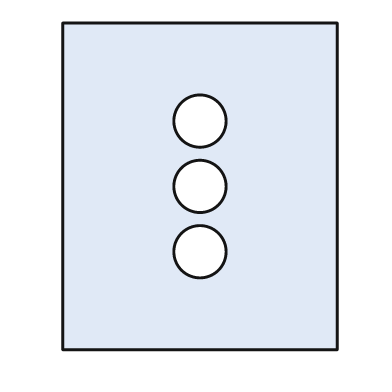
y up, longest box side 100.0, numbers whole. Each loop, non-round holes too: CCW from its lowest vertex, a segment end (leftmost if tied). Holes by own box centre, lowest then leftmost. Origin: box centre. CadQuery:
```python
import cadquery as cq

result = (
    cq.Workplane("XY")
    .moveTo(-42.0, -50.0)
    .lineTo(42.0, -50.0)
    .lineTo(42.0, 50.0)
    .lineTo(-42.0, 50.0)
    .close()
    .moveTo(0.0, -20.0)
    .circle(8.0)
    .moveTo(0.0, 0.0)
    .circle(8.0)
    .moveTo(0.0, 20.0)
    .circle(8.0)
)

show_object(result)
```